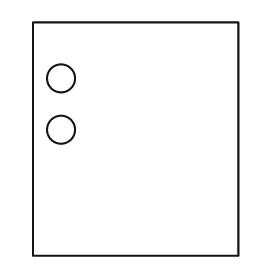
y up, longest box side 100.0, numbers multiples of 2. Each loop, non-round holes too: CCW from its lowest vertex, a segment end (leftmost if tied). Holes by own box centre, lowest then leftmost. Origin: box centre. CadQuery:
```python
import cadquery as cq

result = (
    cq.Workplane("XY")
    .moveTo(-44.0, -50.0)
    .lineTo(44.0, -50.0)
    .lineTo(44.0, 50.0)
    .lineTo(-44.0, 50.0)
    .close()
    .moveTo(-32.0, 4.0)
    .circle(6.0)
    .moveTo(-32.0, 26.0)
    .circle(6.0)
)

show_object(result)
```